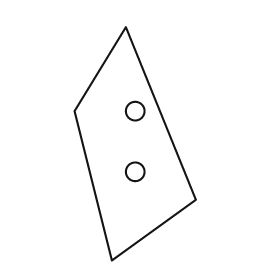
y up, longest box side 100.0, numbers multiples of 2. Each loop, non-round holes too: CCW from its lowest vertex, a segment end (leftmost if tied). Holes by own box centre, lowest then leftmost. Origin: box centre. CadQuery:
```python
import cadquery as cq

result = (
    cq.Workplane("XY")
    .moveTo(-10.0, -50.0)
    .lineTo(26.0, -24.0)
    .lineTo(-4.0, 50.0)
    .lineTo(-26.0, 14.0)
    .close()
    .moveTo(0.0, -12.0)
    .circle(4.0)
    .moveTo(0.0, 14.0)
    .circle(4.0)
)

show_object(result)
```